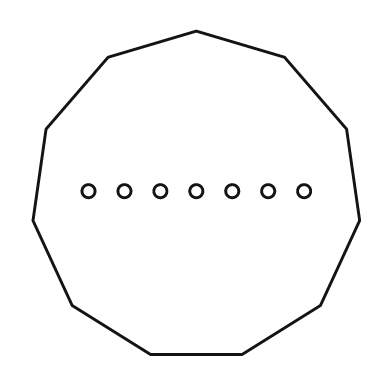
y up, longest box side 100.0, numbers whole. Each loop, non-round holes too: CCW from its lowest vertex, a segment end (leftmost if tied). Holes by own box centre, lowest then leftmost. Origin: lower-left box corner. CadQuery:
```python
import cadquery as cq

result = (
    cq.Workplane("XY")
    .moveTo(36.0, 0.0)
    .lineTo(64.0, 0.0)
    .lineTo(88.0, 15.0)
    .lineTo(100.0, 41.0)
    .lineTo(96.0, 69.0)
    .lineTo(77.0, 91.0)
    .lineTo(50.0, 99.0)
    .lineTo(23.0, 91.0)
    .lineTo(4.0, 69.0)
    .lineTo(0.0, 41.0)
    .lineTo(12.0, 15.0)
    .close()
    .moveTo(17.0, 50.0)
    .circle(2.0)
    .moveTo(28.0, 50.0)
    .circle(2.0)
    .moveTo(39.0, 50.0)
    .circle(2.0)
    .moveTo(50.0, 50.0)
    .circle(2.0)
    .moveTo(61.0, 50.0)
    .circle(2.0)
    .moveTo(72.0, 50.0)
    .circle(2.0)
    .moveTo(83.0, 50.0)
    .circle(2.0)
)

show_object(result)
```